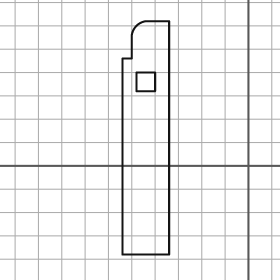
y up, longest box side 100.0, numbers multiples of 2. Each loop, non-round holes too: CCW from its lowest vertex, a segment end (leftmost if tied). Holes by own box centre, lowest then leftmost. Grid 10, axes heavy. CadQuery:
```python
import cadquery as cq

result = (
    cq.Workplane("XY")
    .moveTo(-54.0, -38.0)
    .lineTo(-34.0, -38.0)
    .lineTo(-34.0, 62.0)
    .lineTo(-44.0, 62.0)
    .threePointArc((-48.0, 60.0), (-50.0, 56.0))
    .lineTo(-50.0, 46.0)
    .lineTo(-54.0, 46.0)
    .close()
    .moveTo(-48.0, 32.0)
    .lineTo(-40.0, 32.0)
    .lineTo(-40.0, 40.0)
    .lineTo(-48.0, 40.0)
    .close()
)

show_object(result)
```